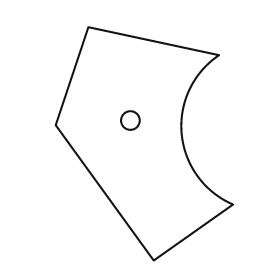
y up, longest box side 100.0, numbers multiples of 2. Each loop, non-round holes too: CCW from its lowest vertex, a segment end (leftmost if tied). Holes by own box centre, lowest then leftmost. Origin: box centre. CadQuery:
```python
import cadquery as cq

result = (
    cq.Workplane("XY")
    .moveTo(4.0, -50.0)
    .lineTo(38.0, -26.0)
    .threePointArc((16.0, 4.0), (32.0, 38.0))
    .lineTo(-24.0, 50.0)
    .lineTo(-38.0, 8.0)
    .close()
    .moveTo(-6.0, 10.0)
    .circle(4.0)
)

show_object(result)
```